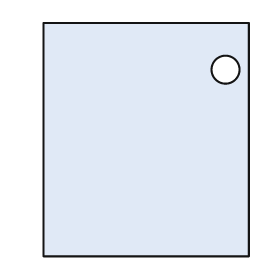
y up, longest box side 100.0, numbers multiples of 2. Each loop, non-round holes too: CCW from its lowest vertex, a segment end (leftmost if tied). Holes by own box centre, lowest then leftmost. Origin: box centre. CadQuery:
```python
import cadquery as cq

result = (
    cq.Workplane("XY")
    .moveTo(-44.0, -50.0)
    .lineTo(44.0, -50.0)
    .lineTo(44.0, 50.0)
    .lineTo(-44.0, 50.0)
    .close()
    .moveTo(34.0, 30.0)
    .circle(6.0)
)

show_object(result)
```